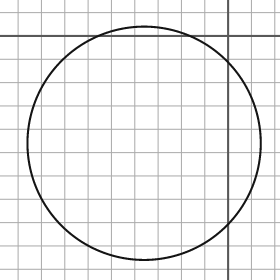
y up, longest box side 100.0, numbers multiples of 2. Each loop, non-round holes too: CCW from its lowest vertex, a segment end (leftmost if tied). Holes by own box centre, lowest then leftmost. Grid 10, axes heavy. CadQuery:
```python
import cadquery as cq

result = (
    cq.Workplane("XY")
    .moveTo(-36.0, -46.0)
    .circle(50.0)
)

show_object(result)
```